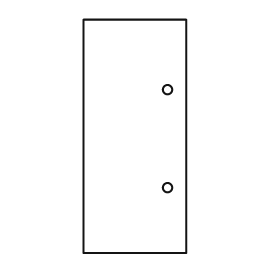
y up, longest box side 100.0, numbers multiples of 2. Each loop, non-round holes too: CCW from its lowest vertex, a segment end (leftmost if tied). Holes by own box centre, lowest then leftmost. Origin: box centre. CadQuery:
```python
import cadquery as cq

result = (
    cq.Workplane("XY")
    .moveTo(-22.0, -50.0)
    .lineTo(22.0, -50.0)
    .lineTo(22.0, 50.0)
    .lineTo(-22.0, 50.0)
    .close()
    .moveTo(14.0, -22.0)
    .circle(2.0)
    .moveTo(14.0, 20.0)
    .circle(2.0)
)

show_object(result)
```